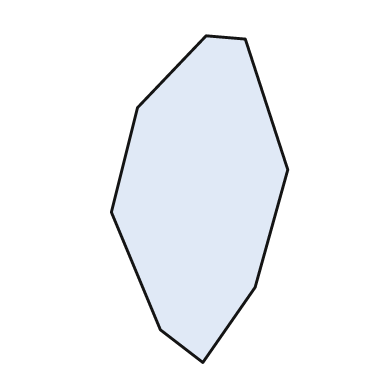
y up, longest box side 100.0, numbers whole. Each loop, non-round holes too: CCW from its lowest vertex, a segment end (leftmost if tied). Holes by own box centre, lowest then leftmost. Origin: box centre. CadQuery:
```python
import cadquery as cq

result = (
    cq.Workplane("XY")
    .moveTo(1.0, -50.0)
    .lineTo(17.0, -27.0)
    .lineTo(27.0, 9.0)
    .lineTo(14.0, 49.0)
    .lineTo(2.0, 50.0)
    .lineTo(-19.0, 28.0)
    .lineTo(-27.0, -4.0)
    .lineTo(-12.0, -40.0)
    .close()
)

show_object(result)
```